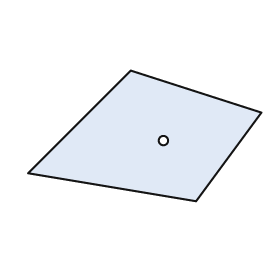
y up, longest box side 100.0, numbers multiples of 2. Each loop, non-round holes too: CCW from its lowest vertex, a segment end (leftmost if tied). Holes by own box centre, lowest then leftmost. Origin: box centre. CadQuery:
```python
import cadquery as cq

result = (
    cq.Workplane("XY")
    .moveTo(22.0, -28.0)
    .lineTo(50.0, 10.0)
    .lineTo(-6.0, 28.0)
    .lineTo(-50.0, -16.0)
    .close()
    .moveTo(8.0, -2.0)
    .circle(2.0)
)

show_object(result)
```